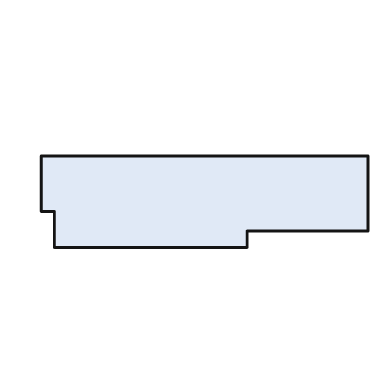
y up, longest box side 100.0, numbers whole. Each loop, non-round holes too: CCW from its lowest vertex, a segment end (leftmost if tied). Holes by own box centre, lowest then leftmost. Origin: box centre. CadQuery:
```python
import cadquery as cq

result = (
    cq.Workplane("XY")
    .moveTo(-46.0, -14.0)
    .lineTo(13.0, -14.0)
    .lineTo(13.0, -9.0)
    .lineTo(50.0, -9.0)
    .lineTo(50.0, 14.0)
    .lineTo(-50.0, 14.0)
    .lineTo(-50.0, -3.0)
    .lineTo(-46.0, -3.0)
    .close()
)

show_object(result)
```